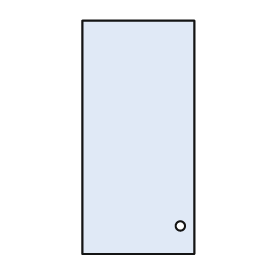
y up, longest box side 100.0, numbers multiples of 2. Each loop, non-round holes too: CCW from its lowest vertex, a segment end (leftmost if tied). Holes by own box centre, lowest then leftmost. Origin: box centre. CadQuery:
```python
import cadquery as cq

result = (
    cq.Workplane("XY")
    .moveTo(-24.0, -50.0)
    .lineTo(24.0, -50.0)
    .lineTo(24.0, 50.0)
    .lineTo(-24.0, 50.0)
    .close()
    .moveTo(18.0, -38.0)
    .circle(2.0)
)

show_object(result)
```